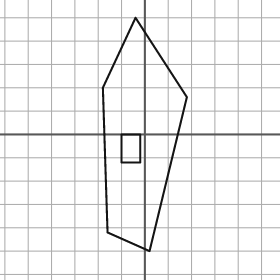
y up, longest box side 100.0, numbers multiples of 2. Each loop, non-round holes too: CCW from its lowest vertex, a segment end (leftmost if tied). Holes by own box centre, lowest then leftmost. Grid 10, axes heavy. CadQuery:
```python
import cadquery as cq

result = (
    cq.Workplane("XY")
    .moveTo(2.0, -50.0)
    .lineTo(18.0, 16.0)
    .lineTo(-4.0, 50.0)
    .lineTo(-18.0, 20.0)
    .lineTo(-16.0, -42.0)
    .close()
    .moveTo(-10.0, -12.0)
    .lineTo(-2.0, -12.0)
    .lineTo(-2.0, 0.0)
    .lineTo(-10.0, 0.0)
    .close()
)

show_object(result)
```